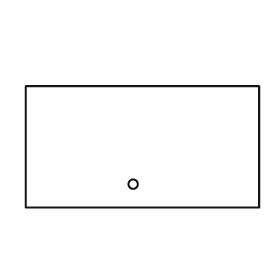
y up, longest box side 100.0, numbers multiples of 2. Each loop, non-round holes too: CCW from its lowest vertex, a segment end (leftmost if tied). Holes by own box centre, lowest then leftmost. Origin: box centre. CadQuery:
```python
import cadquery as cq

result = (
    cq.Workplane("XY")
    .moveTo(-50.0, -26.0)
    .lineTo(50.0, -26.0)
    .lineTo(50.0, 26.0)
    .lineTo(-50.0, 26.0)
    .close()
    .moveTo(-4.0, -16.0)
    .circle(2.0)
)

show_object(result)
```